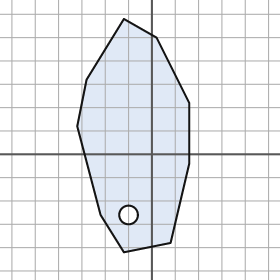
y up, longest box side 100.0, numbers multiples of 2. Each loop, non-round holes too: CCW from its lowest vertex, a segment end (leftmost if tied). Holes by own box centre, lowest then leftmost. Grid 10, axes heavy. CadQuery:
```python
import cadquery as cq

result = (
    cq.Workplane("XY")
    .moveTo(-12.0, -42.0)
    .lineTo(8.0, -38.0)
    .lineTo(16.0, -4.0)
    .lineTo(16.0, 22.0)
    .lineTo(2.0, 50.0)
    .lineTo(-12.0, 58.0)
    .lineTo(-28.0, 32.0)
    .lineTo(-32.0, 12.0)
    .lineTo(-22.0, -26.0)
    .close()
    .moveTo(-10.0, -26.0)
    .circle(4.0)
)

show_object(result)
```